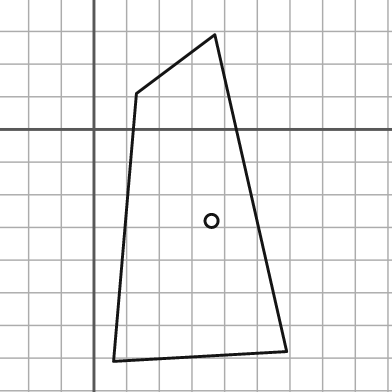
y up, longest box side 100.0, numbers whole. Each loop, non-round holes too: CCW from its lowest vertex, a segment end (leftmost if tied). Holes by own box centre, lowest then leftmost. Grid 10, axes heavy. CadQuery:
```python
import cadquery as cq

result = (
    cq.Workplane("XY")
    .moveTo(6.0, -71.0)
    .lineTo(59.0, -68.0)
    .lineTo(37.0, 29.0)
    .lineTo(13.0, 11.0)
    .close()
    .moveTo(36.0, -28.0)
    .circle(2.0)
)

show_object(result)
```